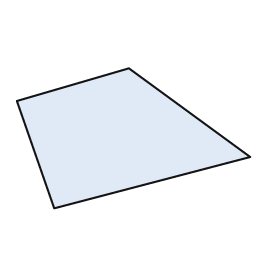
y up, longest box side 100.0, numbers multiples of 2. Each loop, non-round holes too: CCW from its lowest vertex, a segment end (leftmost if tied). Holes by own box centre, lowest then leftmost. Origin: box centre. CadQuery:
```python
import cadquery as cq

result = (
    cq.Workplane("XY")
    .moveTo(-34.0, -30.0)
    .lineTo(50.0, -8.0)
    .lineTo(-2.0, 30.0)
    .lineTo(-50.0, 16.0)
    .close()
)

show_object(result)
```